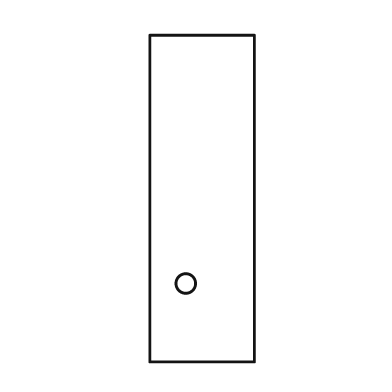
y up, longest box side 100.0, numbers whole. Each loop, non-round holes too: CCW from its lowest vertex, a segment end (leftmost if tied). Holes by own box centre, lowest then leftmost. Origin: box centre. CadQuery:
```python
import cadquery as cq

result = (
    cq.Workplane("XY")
    .moveTo(-16.0, -50.0)
    .lineTo(16.0, -50.0)
    .lineTo(16.0, 50.0)
    .lineTo(-16.0, 50.0)
    .close()
    .moveTo(-5.0, -26.0)
    .circle(3.0)
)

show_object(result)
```